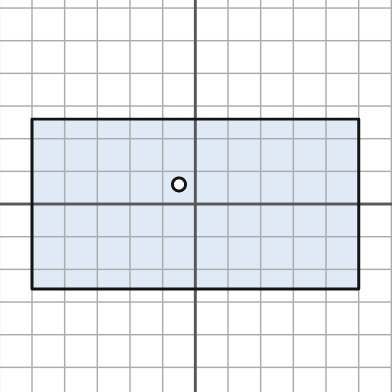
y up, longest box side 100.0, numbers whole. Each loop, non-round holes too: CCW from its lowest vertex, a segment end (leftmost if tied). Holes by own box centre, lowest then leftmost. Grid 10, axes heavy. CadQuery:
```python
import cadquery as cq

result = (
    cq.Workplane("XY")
    .moveTo(-50.0, -26.0)
    .lineTo(50.0, -26.0)
    .lineTo(50.0, 26.0)
    .lineTo(-50.0, 26.0)
    .close()
    .moveTo(-5.0, 6.0)
    .circle(2.0)
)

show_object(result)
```